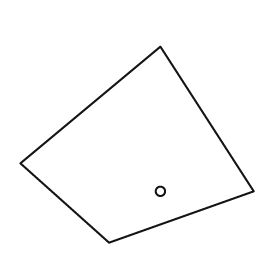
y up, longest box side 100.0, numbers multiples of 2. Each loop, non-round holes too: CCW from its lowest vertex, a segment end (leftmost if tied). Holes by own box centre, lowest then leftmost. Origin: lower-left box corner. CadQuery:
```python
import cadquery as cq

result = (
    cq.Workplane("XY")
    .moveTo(38.0, 0.0)
    .lineTo(100.0, 22.0)
    .lineTo(60.0, 84.0)
    .lineTo(0.0, 34.0)
    .close()
    .moveTo(60.0, 22.0)
    .circle(2.0)
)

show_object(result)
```